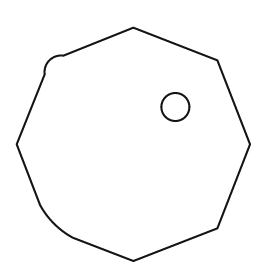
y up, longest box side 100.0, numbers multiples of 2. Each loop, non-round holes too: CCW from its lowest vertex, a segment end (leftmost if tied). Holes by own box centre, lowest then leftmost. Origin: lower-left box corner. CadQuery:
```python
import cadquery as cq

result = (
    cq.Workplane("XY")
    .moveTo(50.0, 0.0)
    .lineTo(86.0, 14.0)
    .lineTo(100.0, 50.0)
    .lineTo(86.0, 86.0)
    .lineTo(50.0, 100.0)
    .lineTo(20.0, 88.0)
    .threePointArc((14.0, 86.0), (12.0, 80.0))
    .lineTo(0.0, 50.0)
    .lineTo(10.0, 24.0)
    .threePointArc((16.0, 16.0), (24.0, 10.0))
    .close()
    .moveTo(68.0, 66.0)
    .circle(6.0)
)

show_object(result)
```